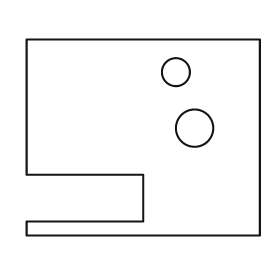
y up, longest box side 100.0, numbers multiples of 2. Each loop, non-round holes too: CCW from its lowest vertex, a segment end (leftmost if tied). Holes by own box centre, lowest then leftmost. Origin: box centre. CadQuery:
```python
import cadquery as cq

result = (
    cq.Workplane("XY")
    .moveTo(-50.0, -42.0)
    .lineTo(50.0, -42.0)
    .lineTo(50.0, 42.0)
    .lineTo(-50.0, 42.0)
    .lineTo(-50.0, -16.0)
    .lineTo(0.0, -16.0)
    .lineTo(0.0, -36.0)
    .lineTo(-50.0, -36.0)
    .close()
    .moveTo(22.0, 4.0)
    .circle(8.0)
    .moveTo(14.0, 28.0)
    .circle(6.0)
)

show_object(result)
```